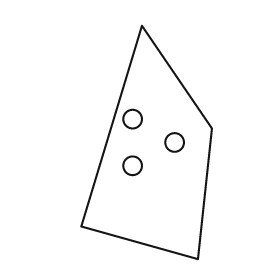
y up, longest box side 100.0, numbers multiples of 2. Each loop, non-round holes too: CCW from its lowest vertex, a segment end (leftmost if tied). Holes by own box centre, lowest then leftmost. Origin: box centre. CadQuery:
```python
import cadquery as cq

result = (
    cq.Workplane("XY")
    .moveTo(22.0, -50.0)
    .lineTo(28.0, 6.0)
    .lineTo(-2.0, 50.0)
    .lineTo(-28.0, -36.0)
    .close()
    .moveTo(-6.0, -10.0)
    .circle(4.0)
    .moveTo(12.0, 0.0)
    .circle(4.0)
    .moveTo(-6.0, 10.0)
    .circle(4.0)
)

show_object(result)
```